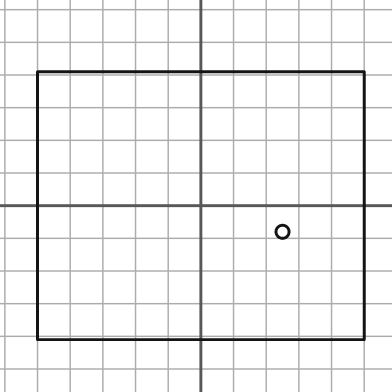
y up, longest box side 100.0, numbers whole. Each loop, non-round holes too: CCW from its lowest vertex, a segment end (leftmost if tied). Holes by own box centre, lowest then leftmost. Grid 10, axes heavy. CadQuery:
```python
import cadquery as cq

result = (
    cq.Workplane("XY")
    .moveTo(-50.0, -41.0)
    .lineTo(50.0, -41.0)
    .lineTo(50.0, 41.0)
    .lineTo(-50.0, 41.0)
    .close()
    .moveTo(25.0, -8.0)
    .circle(2.0)
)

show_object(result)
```